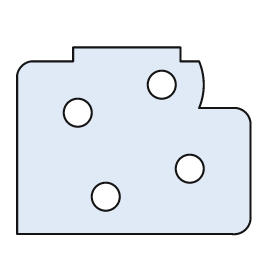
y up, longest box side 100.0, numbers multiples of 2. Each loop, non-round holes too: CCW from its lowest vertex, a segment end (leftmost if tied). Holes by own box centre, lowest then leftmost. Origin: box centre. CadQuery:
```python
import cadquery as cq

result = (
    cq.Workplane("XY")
    .moveTo(-50.0, -40.0)
    .lineTo(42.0, -40.0)
    .threePointArc((48.0, -38.0), (50.0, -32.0))
    .lineTo(50.0, 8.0)
    .threePointArc((48.0, 12.0), (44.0, 14.0))
    .lineTo(28.0, 14.0)
    .threePointArc((30.0, 24.0), (28.0, 34.0))
    .lineTo(20.0, 34.0)
    .lineTo(20.0, 40.0)
    .lineTo(-26.0, 40.0)
    .lineTo(-26.0, 34.0)
    .lineTo(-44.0, 34.0)
    .threePointArc((-48.0, 32.0), (-50.0, 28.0))
    .close()
    .moveTo(-12.0, -24.0)
    .circle(6.0)
    .moveTo(24.0, -12.0)
    .circle(6.0)
    .moveTo(-24.0, 12.0)
    .circle(6.0)
    .moveTo(12.0, 24.0)
    .circle(6.0)
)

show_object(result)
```